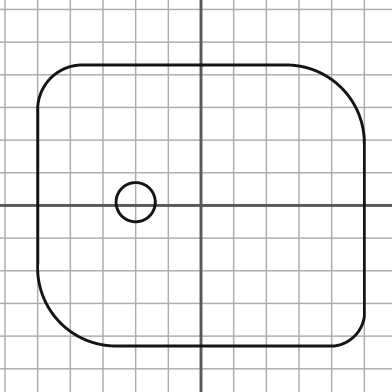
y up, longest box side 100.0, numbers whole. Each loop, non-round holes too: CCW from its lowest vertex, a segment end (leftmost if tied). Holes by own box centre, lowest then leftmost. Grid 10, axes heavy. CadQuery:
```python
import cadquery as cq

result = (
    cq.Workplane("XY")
    .moveTo(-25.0, -43.0)
    .lineTo(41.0, -43.0)
    .threePointArc((47.0, -40.0), (50.0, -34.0))
    .lineTo(50.0, 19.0)
    .threePointArc((43.0, 36.0), (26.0, 43.0))
    .lineTo(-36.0, 43.0)
    .threePointArc((-46.0, 39.0), (-50.0, 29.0))
    .lineTo(-50.0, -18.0)
    .threePointArc((-43.0, -36.0), (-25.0, -43.0))
    .close()
    .moveTo(-20.0, 1.0)
    .circle(6.0)
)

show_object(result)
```